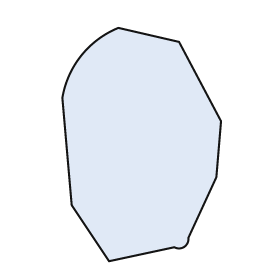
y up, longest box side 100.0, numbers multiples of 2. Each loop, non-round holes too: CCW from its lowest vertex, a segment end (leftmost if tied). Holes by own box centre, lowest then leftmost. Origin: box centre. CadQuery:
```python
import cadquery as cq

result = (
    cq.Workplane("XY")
    .moveTo(-14.0, -50.0)
    .lineTo(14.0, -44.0)
    .threePointArc((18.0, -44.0), (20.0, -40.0))
    .lineTo(32.0, -14.0)
    .lineTo(34.0, 10.0)
    .lineTo(16.0, 44.0)
    .lineTo(-10.0, 50.0)
    .threePointArc((-26.0, 38.0), (-34.0, 20.0))
    .lineTo(-30.0, -26.0)
    .close()
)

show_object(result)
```